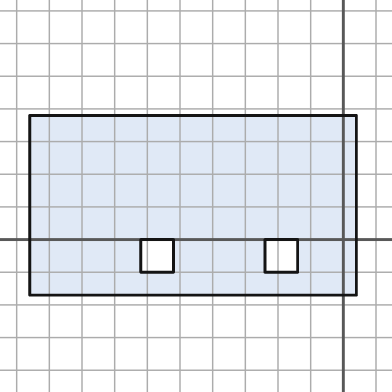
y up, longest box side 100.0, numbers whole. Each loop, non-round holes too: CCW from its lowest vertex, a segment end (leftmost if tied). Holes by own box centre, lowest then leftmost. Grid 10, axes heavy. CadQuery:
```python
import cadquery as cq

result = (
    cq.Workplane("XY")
    .moveTo(-96.0, -17.0)
    .lineTo(4.0, -17.0)
    .lineTo(4.0, 38.0)
    .lineTo(-96.0, 38.0)
    .close()
    .moveTo(-62.0, -10.0)
    .lineTo(-52.0, -10.0)
    .lineTo(-52.0, 0.0)
    .lineTo(-62.0, 0.0)
    .close()
    .moveTo(-24.0, -10.0)
    .lineTo(-14.0, -10.0)
    .lineTo(-14.0, 0.0)
    .lineTo(-24.0, 0.0)
    .close()
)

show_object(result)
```